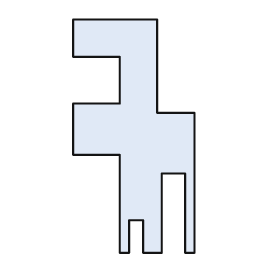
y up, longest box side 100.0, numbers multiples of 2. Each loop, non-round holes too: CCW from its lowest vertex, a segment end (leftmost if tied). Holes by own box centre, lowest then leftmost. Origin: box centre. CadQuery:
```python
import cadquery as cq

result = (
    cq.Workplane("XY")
    .moveTo(-6.0, -50.0)
    .lineTo(-2.0, -50.0)
    .lineTo(-2.0, -36.0)
    .lineTo(4.0, -36.0)
    .lineTo(4.0, -50.0)
    .lineTo(12.0, -50.0)
    .lineTo(12.0, -16.0)
    .lineTo(22.0, -16.0)
    .lineTo(22.0, -50.0)
    .lineTo(26.0, -50.0)
    .lineTo(26.0, 10.0)
    .lineTo(10.0, 10.0)
    .lineTo(10.0, 50.0)
    .lineTo(-26.0, 50.0)
    .lineTo(-26.0, 34.0)
    .lineTo(-6.0, 34.0)
    .lineTo(-6.0, 14.0)
    .lineTo(-26.0, 14.0)
    .lineTo(-26.0, -8.0)
    .lineTo(-6.0, -8.0)
    .close()
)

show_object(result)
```